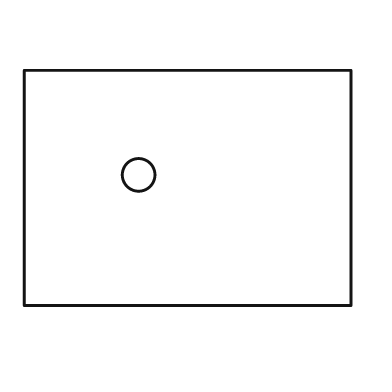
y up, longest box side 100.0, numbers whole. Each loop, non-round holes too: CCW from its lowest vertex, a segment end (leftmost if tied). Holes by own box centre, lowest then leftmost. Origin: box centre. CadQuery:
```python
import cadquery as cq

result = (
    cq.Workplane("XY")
    .moveTo(-50.0, -36.0)
    .lineTo(50.0, -36.0)
    .lineTo(50.0, 36.0)
    .lineTo(-50.0, 36.0)
    .close()
    .moveTo(-15.0, 4.0)
    .circle(5.0)
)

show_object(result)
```